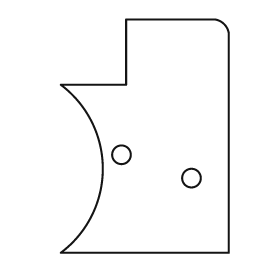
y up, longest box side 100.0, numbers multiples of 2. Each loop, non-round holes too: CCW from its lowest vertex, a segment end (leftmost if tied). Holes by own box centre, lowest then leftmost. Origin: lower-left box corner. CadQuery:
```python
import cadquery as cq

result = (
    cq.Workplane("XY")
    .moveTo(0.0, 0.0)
    .lineTo(72.0, 0.0)
    .lineTo(72.0, 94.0)
    .threePointArc((70.0, 98.0), (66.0, 100.0))
    .lineTo(28.0, 100.0)
    .lineTo(28.0, 72.0)
    .lineTo(0.0, 72.0)
    .threePointArc((18.0, 36.0), (0.0, 0.0))
    .close()
    .moveTo(56.0, 32.0)
    .circle(4.0)
    .moveTo(26.0, 42.0)
    .circle(4.0)
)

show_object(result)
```